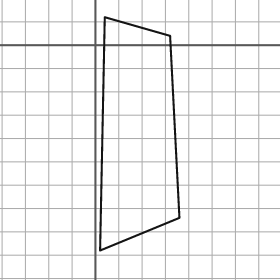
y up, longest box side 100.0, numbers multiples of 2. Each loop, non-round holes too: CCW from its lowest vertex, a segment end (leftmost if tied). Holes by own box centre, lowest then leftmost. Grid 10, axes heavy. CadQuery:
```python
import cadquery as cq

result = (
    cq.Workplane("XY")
    .moveTo(2.0, -88.0)
    .lineTo(36.0, -74.0)
    .lineTo(32.0, 4.0)
    .lineTo(4.0, 12.0)
    .close()
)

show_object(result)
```